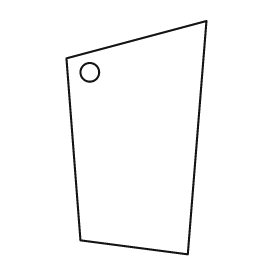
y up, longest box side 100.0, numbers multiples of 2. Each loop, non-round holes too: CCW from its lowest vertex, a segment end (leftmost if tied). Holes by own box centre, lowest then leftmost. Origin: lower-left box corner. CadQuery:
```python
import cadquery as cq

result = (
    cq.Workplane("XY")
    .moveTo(52.0, 0.0)
    .lineTo(60.0, 100.0)
    .lineTo(0.0, 84.0)
    .lineTo(6.0, 6.0)
    .close()
    .moveTo(10.0, 78.0)
    .circle(4.0)
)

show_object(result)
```